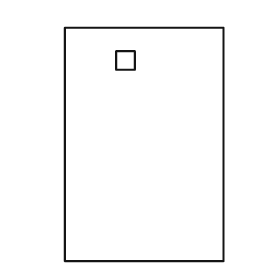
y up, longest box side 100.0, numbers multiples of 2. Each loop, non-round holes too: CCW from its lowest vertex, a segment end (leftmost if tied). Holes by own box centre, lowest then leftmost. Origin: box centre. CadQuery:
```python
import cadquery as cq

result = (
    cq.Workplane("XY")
    .moveTo(-34.0, -50.0)
    .lineTo(34.0, -50.0)
    .lineTo(34.0, 50.0)
    .lineTo(-34.0, 50.0)
    .close()
    .moveTo(-12.0, 32.0)
    .lineTo(-4.0, 32.0)
    .lineTo(-4.0, 40.0)
    .lineTo(-12.0, 40.0)
    .close()
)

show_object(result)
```